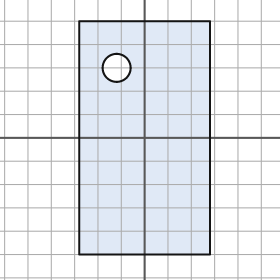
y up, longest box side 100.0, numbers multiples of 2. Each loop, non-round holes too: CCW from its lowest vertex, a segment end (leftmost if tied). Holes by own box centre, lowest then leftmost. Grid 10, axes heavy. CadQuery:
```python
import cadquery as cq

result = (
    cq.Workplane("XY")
    .moveTo(-28.0, -50.0)
    .lineTo(28.0, -50.0)
    .lineTo(28.0, 50.0)
    .lineTo(-28.0, 50.0)
    .close()
    .moveTo(-12.0, 30.0)
    .circle(6.0)
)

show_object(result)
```